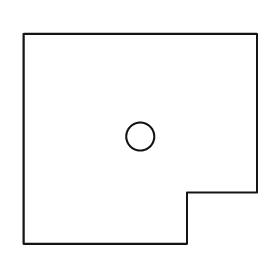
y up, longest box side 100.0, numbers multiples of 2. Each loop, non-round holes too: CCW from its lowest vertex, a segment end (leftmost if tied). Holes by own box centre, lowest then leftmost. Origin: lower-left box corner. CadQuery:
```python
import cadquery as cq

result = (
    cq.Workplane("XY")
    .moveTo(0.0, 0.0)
    .lineTo(70.0, 0.0)
    .lineTo(70.0, 22.0)
    .lineTo(100.0, 22.0)
    .lineTo(100.0, 90.0)
    .lineTo(0.0, 90.0)
    .close()
    .moveTo(50.0, 46.0)
    .circle(6.0)
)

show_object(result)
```